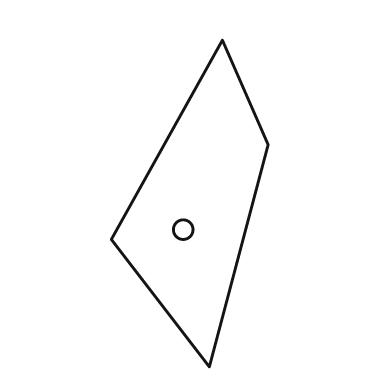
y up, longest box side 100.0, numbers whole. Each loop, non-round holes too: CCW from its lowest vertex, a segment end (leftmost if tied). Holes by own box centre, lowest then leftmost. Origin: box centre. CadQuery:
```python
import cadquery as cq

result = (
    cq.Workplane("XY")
    .moveTo(6.0, -50.0)
    .lineTo(24.0, 18.0)
    .lineTo(10.0, 50.0)
    .lineTo(-24.0, -11.0)
    .close()
    .moveTo(-2.0, -8.0)
    .circle(3.0)
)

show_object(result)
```